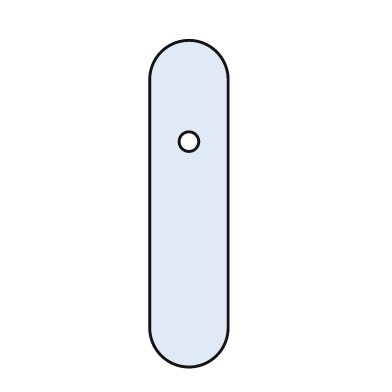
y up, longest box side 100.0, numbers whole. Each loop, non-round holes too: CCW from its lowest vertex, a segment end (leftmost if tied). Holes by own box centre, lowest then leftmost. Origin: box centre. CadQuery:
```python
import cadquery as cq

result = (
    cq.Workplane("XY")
    .moveTo(-12.0, -38.0)
    .threePointArc((0.0, -50.0), (12.0, -38.0))
    .lineTo(12.0, 38.0)
    .threePointArc((0.0, 50.0), (-12.0, 38.0))
    .close()
    .moveTo(0.0, 19.0)
    .circle(3.0)
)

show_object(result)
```